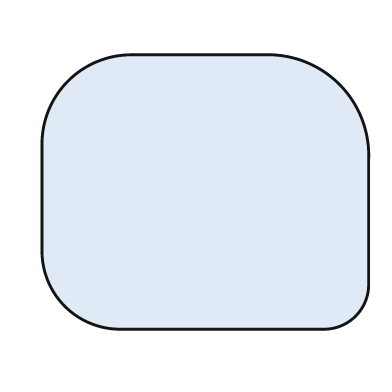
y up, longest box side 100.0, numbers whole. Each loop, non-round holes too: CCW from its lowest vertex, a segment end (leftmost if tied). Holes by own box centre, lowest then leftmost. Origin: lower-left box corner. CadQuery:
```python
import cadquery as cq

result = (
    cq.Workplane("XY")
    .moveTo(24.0, 0.0)
    .lineTo(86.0, 0.0)
    .threePointArc((96.0, 4.0), (100.0, 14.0))
    .lineTo(100.0, 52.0)
    .threePointArc((91.0, 75.0), (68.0, 84.0))
    .lineTo(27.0, 84.0)
    .threePointArc((8.0, 76.0), (0.0, 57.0))
    .lineTo(0.0, 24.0)
    .threePointArc((7.0, 7.0), (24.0, 0.0))
    .close()
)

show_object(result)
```